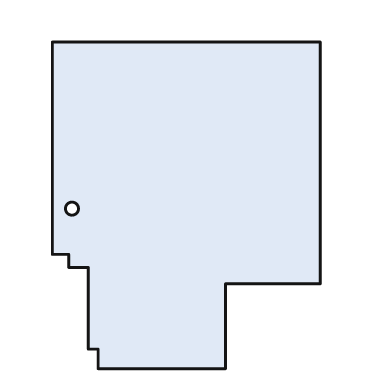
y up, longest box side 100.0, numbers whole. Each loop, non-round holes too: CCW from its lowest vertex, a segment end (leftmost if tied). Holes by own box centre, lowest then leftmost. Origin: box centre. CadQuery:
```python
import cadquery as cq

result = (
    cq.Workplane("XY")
    .moveTo(-27.0, -50.0)
    .lineTo(12.0, -50.0)
    .lineTo(12.0, -24.0)
    .lineTo(41.0, -24.0)
    .lineTo(41.0, 50.0)
    .lineTo(-41.0, 50.0)
    .lineTo(-41.0, -15.0)
    .lineTo(-36.0, -15.0)
    .lineTo(-36.0, -19.0)
    .lineTo(-30.0, -19.0)
    .lineTo(-30.0, -44.0)
    .lineTo(-27.0, -44.0)
    .close()
    .moveTo(-35.0, -1.0)
    .circle(2.0)
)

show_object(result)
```